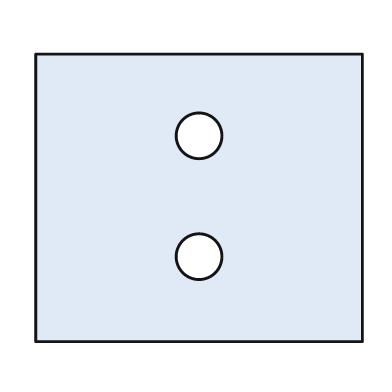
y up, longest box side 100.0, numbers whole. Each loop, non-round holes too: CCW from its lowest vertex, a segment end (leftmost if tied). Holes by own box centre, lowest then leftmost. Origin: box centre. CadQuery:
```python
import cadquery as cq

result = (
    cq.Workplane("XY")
    .moveTo(-50.0, -44.0)
    .lineTo(50.0, -44.0)
    .lineTo(50.0, 44.0)
    .lineTo(-50.0, 44.0)
    .close()
    .moveTo(0.0, -18.0)
    .circle(7.0)
    .moveTo(0.0, 19.0)
    .circle(7.0)
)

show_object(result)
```